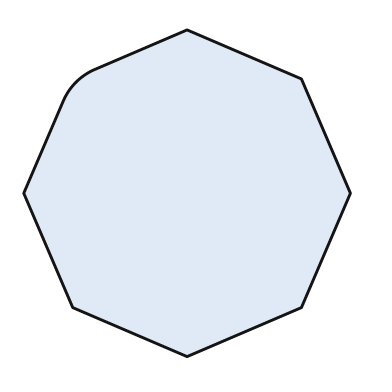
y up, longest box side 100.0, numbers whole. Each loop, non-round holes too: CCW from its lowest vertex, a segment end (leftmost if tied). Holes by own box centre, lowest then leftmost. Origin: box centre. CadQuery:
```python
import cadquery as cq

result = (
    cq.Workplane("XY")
    .moveTo(0.0, -50.0)
    .lineTo(35.0, -35.0)
    .lineTo(50.0, 0.0)
    .lineTo(35.0, 35.0)
    .lineTo(0.0, 50.0)
    .lineTo(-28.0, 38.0)
    .threePointArc((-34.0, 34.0), (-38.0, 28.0))
    .lineTo(-50.0, 0.0)
    .lineTo(-35.0, -35.0)
    .close()
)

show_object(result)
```